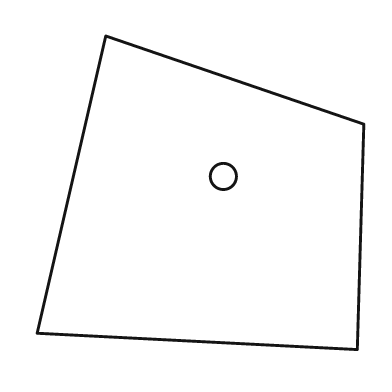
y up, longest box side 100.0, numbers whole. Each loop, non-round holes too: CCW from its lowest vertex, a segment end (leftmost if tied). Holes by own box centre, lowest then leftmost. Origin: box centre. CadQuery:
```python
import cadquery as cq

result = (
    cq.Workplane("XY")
    .moveTo(48.0, -48.0)
    .lineTo(50.0, 21.0)
    .lineTo(-29.0, 48.0)
    .lineTo(-50.0, -43.0)
    .close()
    .moveTo(7.0, 5.0)
    .circle(4.0)
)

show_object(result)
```